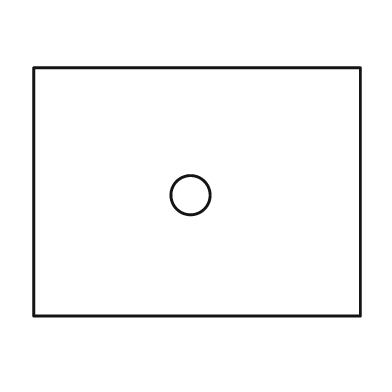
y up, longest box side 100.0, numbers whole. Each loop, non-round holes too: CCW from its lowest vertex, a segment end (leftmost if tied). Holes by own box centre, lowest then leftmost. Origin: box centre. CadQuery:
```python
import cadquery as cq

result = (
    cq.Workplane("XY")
    .moveTo(-50.0, -38.0)
    .lineTo(50.0, -38.0)
    .lineTo(50.0, 38.0)
    .lineTo(-50.0, 38.0)
    .close()
    .moveTo(-2.0, -1.0)
    .circle(6.0)
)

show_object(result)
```